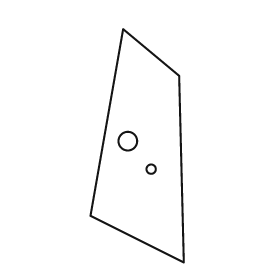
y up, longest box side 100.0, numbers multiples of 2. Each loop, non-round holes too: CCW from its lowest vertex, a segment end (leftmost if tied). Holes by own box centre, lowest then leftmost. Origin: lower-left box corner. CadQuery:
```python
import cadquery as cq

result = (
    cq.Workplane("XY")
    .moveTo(40.0, 0.0)
    .lineTo(38.0, 80.0)
    .lineTo(14.0, 100.0)
    .lineTo(0.0, 20.0)
    .close()
    .moveTo(26.0, 40.0)
    .circle(2.0)
    .moveTo(16.0, 52.0)
    .circle(4.0)
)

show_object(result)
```